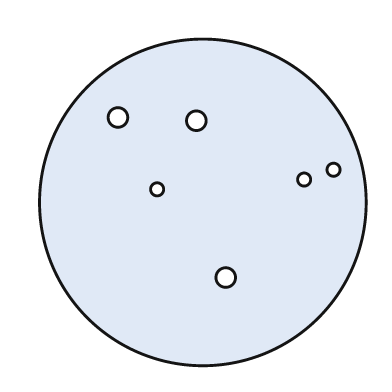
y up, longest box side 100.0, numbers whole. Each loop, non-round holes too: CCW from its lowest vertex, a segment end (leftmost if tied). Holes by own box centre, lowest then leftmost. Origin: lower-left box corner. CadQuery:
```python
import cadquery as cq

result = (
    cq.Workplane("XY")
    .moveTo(50.0, 50.0)
    .circle(50.0)
    .moveTo(57.0, 27.0)
    .circle(3.0)
    .moveTo(36.0, 54.0)
    .circle(2.0)
    .moveTo(81.0, 57.0)
    .circle(2.0)
    .moveTo(90.0, 60.0)
    .circle(2.0)
    .moveTo(48.0, 75.0)
    .circle(3.0)
    .moveTo(24.0, 76.0)
    .circle(3.0)
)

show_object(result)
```